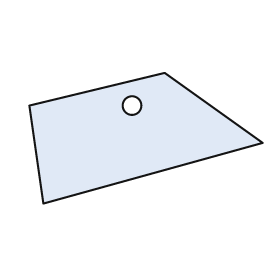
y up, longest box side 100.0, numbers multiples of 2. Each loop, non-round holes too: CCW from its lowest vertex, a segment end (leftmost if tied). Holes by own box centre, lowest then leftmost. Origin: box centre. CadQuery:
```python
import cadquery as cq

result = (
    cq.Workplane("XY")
    .moveTo(-44.0, -28.0)
    .lineTo(50.0, -2.0)
    .lineTo(8.0, 28.0)
    .lineTo(-50.0, 14.0)
    .close()
    .moveTo(-6.0, 14.0)
    .circle(4.0)
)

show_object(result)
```